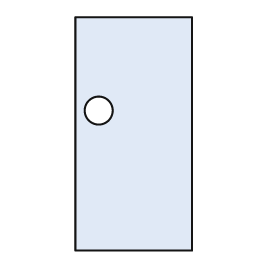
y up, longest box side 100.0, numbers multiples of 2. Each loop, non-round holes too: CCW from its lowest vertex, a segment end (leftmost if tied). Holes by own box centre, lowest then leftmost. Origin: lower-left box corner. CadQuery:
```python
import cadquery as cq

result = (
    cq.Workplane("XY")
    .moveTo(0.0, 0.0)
    .lineTo(50.0, 0.0)
    .lineTo(50.0, 100.0)
    .lineTo(0.0, 100.0)
    .close()
    .moveTo(10.0, 60.0)
    .circle(6.0)
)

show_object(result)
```